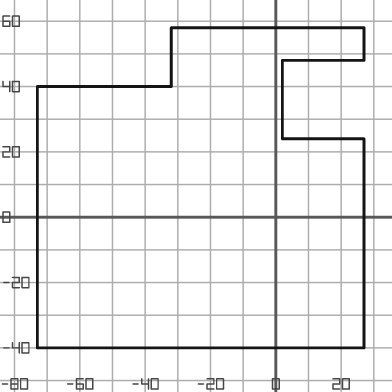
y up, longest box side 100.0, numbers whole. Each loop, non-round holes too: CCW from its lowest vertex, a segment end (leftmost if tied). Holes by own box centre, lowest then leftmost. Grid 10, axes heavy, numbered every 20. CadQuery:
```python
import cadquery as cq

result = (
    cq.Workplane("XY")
    .moveTo(-73.0, -40.0)
    .lineTo(27.0, -40.0)
    .lineTo(27.0, 24.0)
    .lineTo(2.0, 24.0)
    .lineTo(2.0, 48.0)
    .lineTo(27.0, 48.0)
    .lineTo(27.0, 58.0)
    .lineTo(-32.0, 58.0)
    .lineTo(-32.0, 40.0)
    .lineTo(-73.0, 40.0)
    .close()
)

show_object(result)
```